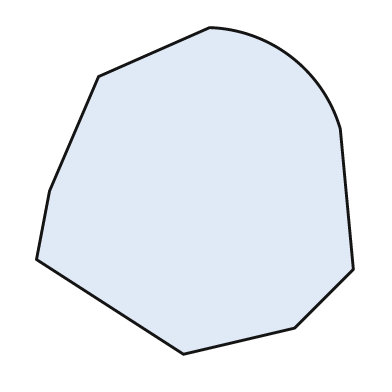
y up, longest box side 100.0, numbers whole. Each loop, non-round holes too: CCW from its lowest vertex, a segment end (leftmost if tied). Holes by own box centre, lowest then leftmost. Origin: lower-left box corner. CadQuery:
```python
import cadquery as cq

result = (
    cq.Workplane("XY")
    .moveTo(45.0, 0.0)
    .lineTo(79.0, 8.0)
    .lineTo(97.0, 26.0)
    .lineTo(93.0, 69.0)
    .threePointArc((78.0, 91.0), (53.0, 100.0))
    .lineTo(19.0, 85.0)
    .lineTo(4.0, 50.0)
    .lineTo(0.0, 29.0)
    .close()
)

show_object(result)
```